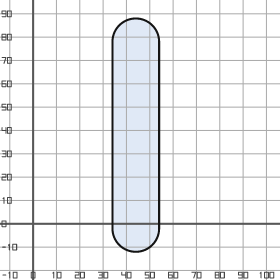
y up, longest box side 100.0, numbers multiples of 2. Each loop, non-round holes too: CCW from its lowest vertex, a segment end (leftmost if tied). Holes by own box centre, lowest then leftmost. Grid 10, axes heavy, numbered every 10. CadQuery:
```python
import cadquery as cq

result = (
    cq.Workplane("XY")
    .moveTo(34.0, -2.0)
    .threePointArc((44.0, -12.0), (54.0, -2.0))
    .lineTo(54.0, 78.0)
    .threePointArc((44.0, 88.0), (34.0, 78.0))
    .close()
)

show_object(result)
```